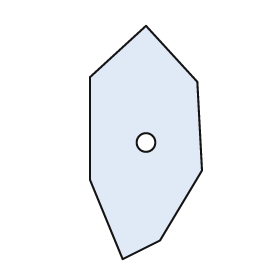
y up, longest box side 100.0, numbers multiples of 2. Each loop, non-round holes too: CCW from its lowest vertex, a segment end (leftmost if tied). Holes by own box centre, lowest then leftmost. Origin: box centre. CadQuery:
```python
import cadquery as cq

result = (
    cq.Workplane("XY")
    .moveTo(-10.0, -50.0)
    .lineTo(6.0, -42.0)
    .lineTo(24.0, -12.0)
    .lineTo(22.0, 26.0)
    .lineTo(0.0, 50.0)
    .lineTo(-24.0, 28.0)
    .lineTo(-24.0, -16.0)
    .close()
    .moveTo(0.0, 0.0)
    .circle(4.0)
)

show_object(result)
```